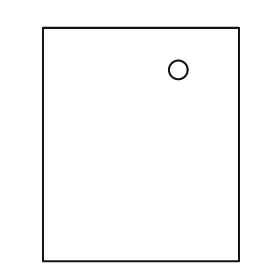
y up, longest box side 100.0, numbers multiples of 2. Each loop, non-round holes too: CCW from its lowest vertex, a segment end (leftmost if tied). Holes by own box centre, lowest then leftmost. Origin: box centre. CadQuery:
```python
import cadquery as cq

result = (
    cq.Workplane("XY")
    .moveTo(-42.0, -50.0)
    .lineTo(42.0, -50.0)
    .lineTo(42.0, 50.0)
    .lineTo(-42.0, 50.0)
    .close()
    .moveTo(16.0, 32.0)
    .circle(4.0)
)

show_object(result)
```